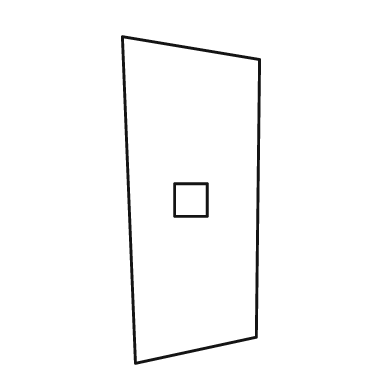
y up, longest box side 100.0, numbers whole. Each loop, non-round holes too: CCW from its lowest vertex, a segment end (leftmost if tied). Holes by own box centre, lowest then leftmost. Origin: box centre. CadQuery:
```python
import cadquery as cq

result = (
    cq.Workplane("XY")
    .moveTo(-17.0, -50.0)
    .lineTo(20.0, -42.0)
    .lineTo(21.0, 43.0)
    .lineTo(-21.0, 50.0)
    .close()
    .moveTo(-5.0, -5.0)
    .lineTo(5.0, -5.0)
    .lineTo(5.0, 5.0)
    .lineTo(-5.0, 5.0)
    .close()
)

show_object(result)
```